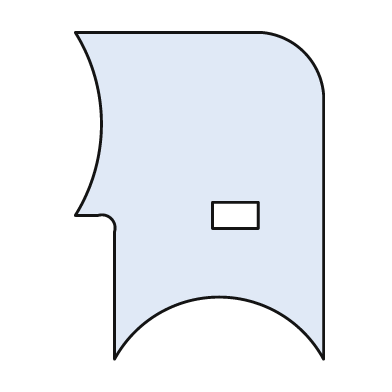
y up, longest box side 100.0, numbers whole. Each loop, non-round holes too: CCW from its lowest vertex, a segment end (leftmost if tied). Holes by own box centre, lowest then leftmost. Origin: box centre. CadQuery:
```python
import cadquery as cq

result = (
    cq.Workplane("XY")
    .moveTo(-26.0, -50.0)
    .threePointArc((6.0, -31.0), (38.0, -50.0))
    .lineTo(38.0, 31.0)
    .threePointArc((32.0, 44.0), (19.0, 50.0))
    .lineTo(-38.0, 50.0)
    .threePointArc((-30.0, 22.0), (-38.0, -6.0))
    .lineTo(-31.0, -6.0)
    .threePointArc((-27.0, -7.0), (-26.0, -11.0))
    .close()
    .moveTo(4.0, -10.0)
    .lineTo(18.0, -10.0)
    .lineTo(18.0, -2.0)
    .lineTo(4.0, -2.0)
    .close()
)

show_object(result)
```